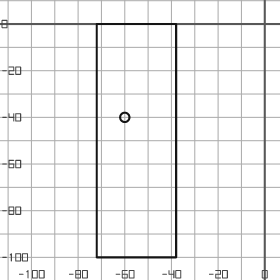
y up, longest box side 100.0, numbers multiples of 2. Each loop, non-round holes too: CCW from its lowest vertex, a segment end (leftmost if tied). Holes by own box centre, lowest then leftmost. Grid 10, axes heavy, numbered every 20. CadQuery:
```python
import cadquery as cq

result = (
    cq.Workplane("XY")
    .moveTo(-72.0, -100.0)
    .lineTo(-38.0, -100.0)
    .lineTo(-38.0, 0.0)
    .lineTo(-72.0, 0.0)
    .close()
    .moveTo(-60.0, -40.0)
    .circle(2.0)
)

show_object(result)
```